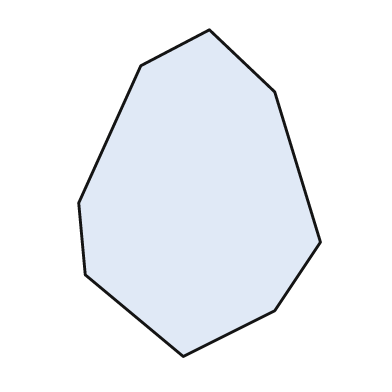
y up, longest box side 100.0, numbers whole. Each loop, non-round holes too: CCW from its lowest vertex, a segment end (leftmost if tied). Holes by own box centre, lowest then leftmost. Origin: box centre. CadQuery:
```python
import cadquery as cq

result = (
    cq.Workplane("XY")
    .moveTo(-5.0, -50.0)
    .lineTo(23.0, -36.0)
    .lineTo(37.0, -15.0)
    .lineTo(23.0, 31.0)
    .lineTo(3.0, 50.0)
    .lineTo(-18.0, 39.0)
    .lineTo(-37.0, -3.0)
    .lineTo(-35.0, -25.0)
    .close()
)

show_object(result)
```